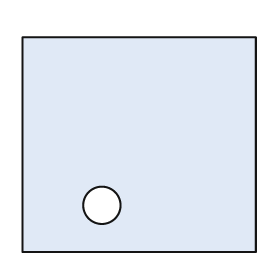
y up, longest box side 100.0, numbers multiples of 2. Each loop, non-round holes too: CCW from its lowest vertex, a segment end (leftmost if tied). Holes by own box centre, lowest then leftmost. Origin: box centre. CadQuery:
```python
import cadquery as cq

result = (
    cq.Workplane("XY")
    .moveTo(-50.0, -46.0)
    .lineTo(50.0, -46.0)
    .lineTo(50.0, 46.0)
    .lineTo(-50.0, 46.0)
    .close()
    .moveTo(-16.0, -26.0)
    .circle(8.0)
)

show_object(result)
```